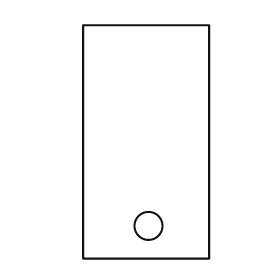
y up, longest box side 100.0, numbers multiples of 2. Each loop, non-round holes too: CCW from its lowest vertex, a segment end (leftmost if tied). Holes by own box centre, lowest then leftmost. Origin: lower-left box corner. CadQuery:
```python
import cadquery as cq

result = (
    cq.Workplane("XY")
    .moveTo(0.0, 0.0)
    .lineTo(54.0, 0.0)
    .lineTo(54.0, 100.0)
    .lineTo(0.0, 100.0)
    .close()
    .moveTo(28.0, 14.0)
    .circle(6.0)
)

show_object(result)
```